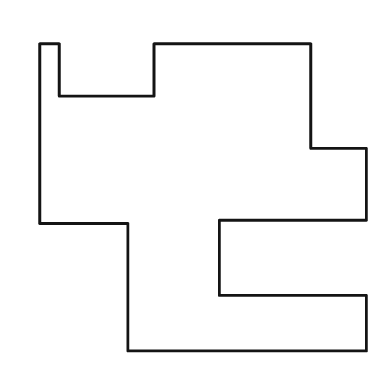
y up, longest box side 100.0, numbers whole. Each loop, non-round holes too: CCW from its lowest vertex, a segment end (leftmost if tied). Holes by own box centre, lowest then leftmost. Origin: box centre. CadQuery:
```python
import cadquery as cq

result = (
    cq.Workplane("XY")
    .moveTo(-23.0, -47.0)
    .lineTo(50.0, -47.0)
    .lineTo(50.0, -30.0)
    .lineTo(5.0, -30.0)
    .lineTo(5.0, -7.0)
    .lineTo(50.0, -7.0)
    .lineTo(50.0, 15.0)
    .lineTo(33.0, 15.0)
    .lineTo(33.0, 47.0)
    .lineTo(-15.0, 47.0)
    .lineTo(-15.0, 31.0)
    .lineTo(-44.0, 31.0)
    .lineTo(-44.0, 47.0)
    .lineTo(-50.0, 47.0)
    .lineTo(-50.0, -8.0)
    .lineTo(-23.0, -8.0)
    .close()
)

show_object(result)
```